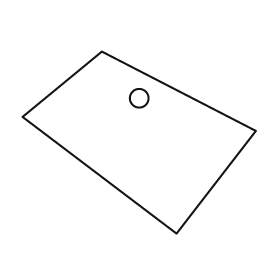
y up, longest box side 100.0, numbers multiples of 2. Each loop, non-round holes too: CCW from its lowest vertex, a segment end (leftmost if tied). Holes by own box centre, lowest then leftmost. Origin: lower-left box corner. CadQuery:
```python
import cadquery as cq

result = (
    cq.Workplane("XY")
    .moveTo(66.0, 0.0)
    .lineTo(100.0, 44.0)
    .lineTo(34.0, 78.0)
    .lineTo(0.0, 50.0)
    .close()
    .moveTo(50.0, 58.0)
    .circle(4.0)
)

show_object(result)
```